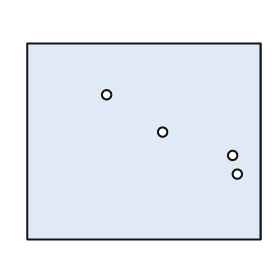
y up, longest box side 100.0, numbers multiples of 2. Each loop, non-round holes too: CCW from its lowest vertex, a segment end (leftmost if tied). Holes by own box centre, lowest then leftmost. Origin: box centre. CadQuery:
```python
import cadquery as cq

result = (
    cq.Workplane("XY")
    .moveTo(-50.0, -42.0)
    .lineTo(50.0, -42.0)
    .lineTo(50.0, 42.0)
    .lineTo(-50.0, 42.0)
    .close()
    .moveTo(40.0, -14.0)
    .circle(2.0)
    .moveTo(38.0, -6.0)
    .circle(2.0)
    .moveTo(8.0, 4.0)
    .circle(2.0)
    .moveTo(-16.0, 20.0)
    .circle(2.0)
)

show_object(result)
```